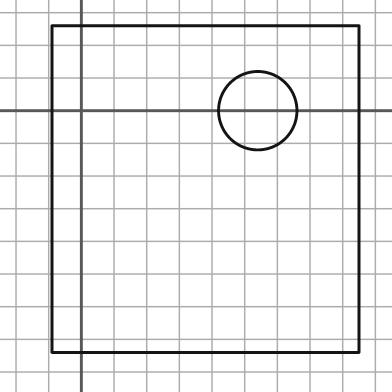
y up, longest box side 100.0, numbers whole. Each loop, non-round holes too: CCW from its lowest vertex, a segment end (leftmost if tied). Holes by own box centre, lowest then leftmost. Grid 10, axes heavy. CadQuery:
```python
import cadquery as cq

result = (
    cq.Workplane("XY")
    .moveTo(-9.0, -74.0)
    .lineTo(85.0, -74.0)
    .lineTo(85.0, 26.0)
    .lineTo(-9.0, 26.0)
    .close()
    .moveTo(54.0, 0.0)
    .circle(12.0)
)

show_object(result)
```